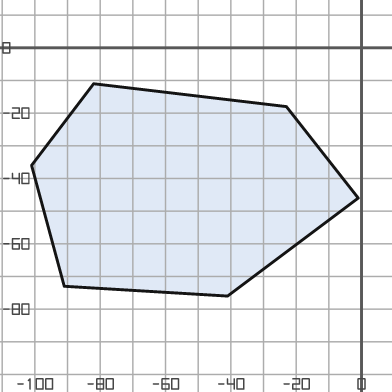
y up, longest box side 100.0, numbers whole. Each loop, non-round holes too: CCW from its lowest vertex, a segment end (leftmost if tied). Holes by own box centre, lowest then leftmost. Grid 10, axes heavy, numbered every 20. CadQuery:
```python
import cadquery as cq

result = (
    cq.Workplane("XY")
    .moveTo(-41.0, -76.0)
    .lineTo(-1.0, -46.0)
    .lineTo(-23.0, -18.0)
    .lineTo(-82.0, -11.0)
    .lineTo(-101.0, -36.0)
    .lineTo(-91.0, -73.0)
    .close()
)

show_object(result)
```